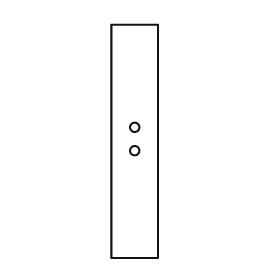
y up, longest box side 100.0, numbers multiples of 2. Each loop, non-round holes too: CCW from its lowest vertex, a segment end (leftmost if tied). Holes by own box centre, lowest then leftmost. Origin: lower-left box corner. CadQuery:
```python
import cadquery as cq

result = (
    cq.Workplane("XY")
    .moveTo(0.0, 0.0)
    .lineTo(20.0, 0.0)
    .lineTo(20.0, 100.0)
    .lineTo(0.0, 100.0)
    .close()
    .moveTo(10.0, 46.0)
    .circle(2.0)
    .moveTo(10.0, 56.0)
    .circle(2.0)
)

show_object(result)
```